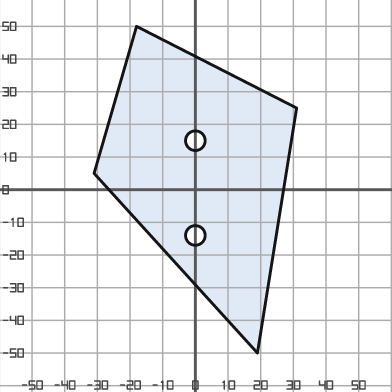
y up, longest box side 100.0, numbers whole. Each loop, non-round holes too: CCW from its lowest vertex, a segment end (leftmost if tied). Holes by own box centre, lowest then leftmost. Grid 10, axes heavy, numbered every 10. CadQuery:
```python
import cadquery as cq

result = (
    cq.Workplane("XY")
    .moveTo(19.0, -50.0)
    .lineTo(31.0, 25.0)
    .lineTo(-18.0, 50.0)
    .lineTo(-31.0, 5.0)
    .close()
    .moveTo(0.0, -14.0)
    .circle(3.0)
    .moveTo(0.0, 15.0)
    .circle(3.0)
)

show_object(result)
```